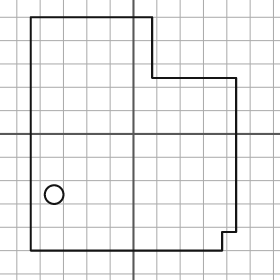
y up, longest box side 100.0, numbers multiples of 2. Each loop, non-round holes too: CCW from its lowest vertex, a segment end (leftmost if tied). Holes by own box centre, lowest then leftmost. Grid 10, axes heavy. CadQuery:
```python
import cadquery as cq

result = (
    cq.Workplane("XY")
    .moveTo(-44.0, -50.0)
    .lineTo(38.0, -50.0)
    .lineTo(38.0, -42.0)
    .lineTo(44.0, -42.0)
    .lineTo(44.0, 24.0)
    .lineTo(8.0, 24.0)
    .lineTo(8.0, 50.0)
    .lineTo(-44.0, 50.0)
    .close()
    .moveTo(-34.0, -26.0)
    .circle(4.0)
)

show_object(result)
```